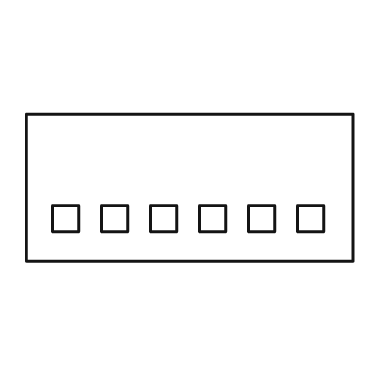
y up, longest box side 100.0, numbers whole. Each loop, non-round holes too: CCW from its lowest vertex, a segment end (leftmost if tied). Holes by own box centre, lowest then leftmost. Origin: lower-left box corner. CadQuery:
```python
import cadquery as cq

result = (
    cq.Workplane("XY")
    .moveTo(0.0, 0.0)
    .lineTo(100.0, 0.0)
    .lineTo(100.0, 45.0)
    .lineTo(0.0, 45.0)
    .close()
    .moveTo(8.0, 9.0)
    .lineTo(16.0, 9.0)
    .lineTo(16.0, 17.0)
    .lineTo(8.0, 17.0)
    .close()
    .moveTo(23.0, 9.0)
    .lineTo(31.0, 9.0)
    .lineTo(31.0, 17.0)
    .lineTo(23.0, 17.0)
    .close()
    .moveTo(38.0, 9.0)
    .lineTo(46.0, 9.0)
    .lineTo(46.0, 17.0)
    .lineTo(38.0, 17.0)
    .close()
    .moveTo(53.0, 9.0)
    .lineTo(61.0, 9.0)
    .lineTo(61.0, 17.0)
    .lineTo(53.0, 17.0)
    .close()
    .moveTo(68.0, 9.0)
    .lineTo(76.0, 9.0)
    .lineTo(76.0, 17.0)
    .lineTo(68.0, 17.0)
    .close()
    .moveTo(83.0, 9.0)
    .lineTo(91.0, 9.0)
    .lineTo(91.0, 17.0)
    .lineTo(83.0, 17.0)
    .close()
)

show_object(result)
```